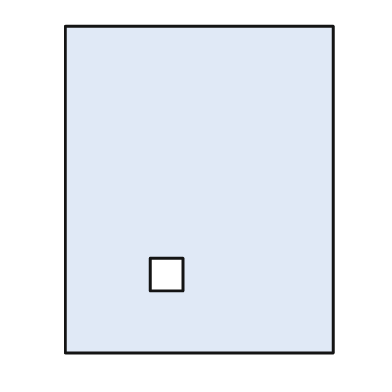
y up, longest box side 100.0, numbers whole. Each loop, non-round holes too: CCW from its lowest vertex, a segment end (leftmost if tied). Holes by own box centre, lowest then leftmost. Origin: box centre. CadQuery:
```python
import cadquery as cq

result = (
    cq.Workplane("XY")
    .moveTo(-41.0, -50.0)
    .lineTo(41.0, -50.0)
    .lineTo(41.0, 50.0)
    .lineTo(-41.0, 50.0)
    .close()
    .moveTo(-15.0, -31.0)
    .lineTo(-5.0, -31.0)
    .lineTo(-5.0, -21.0)
    .lineTo(-15.0, -21.0)
    .close()
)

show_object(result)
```